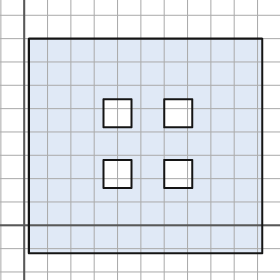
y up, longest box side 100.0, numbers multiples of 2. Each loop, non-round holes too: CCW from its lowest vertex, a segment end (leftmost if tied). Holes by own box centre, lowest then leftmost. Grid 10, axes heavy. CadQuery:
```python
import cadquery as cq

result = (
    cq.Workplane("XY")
    .moveTo(2.0, -12.0)
    .lineTo(102.0, -12.0)
    .lineTo(102.0, 80.0)
    .lineTo(2.0, 80.0)
    .close()
    .moveTo(34.0, 16.0)
    .lineTo(46.0, 16.0)
    .lineTo(46.0, 28.0)
    .lineTo(34.0, 28.0)
    .close()
    .moveTo(60.0, 16.0)
    .lineTo(72.0, 16.0)
    .lineTo(72.0, 28.0)
    .lineTo(60.0, 28.0)
    .close()
    .moveTo(34.0, 42.0)
    .lineTo(46.0, 42.0)
    .lineTo(46.0, 54.0)
    .lineTo(34.0, 54.0)
    .close()
    .moveTo(60.0, 42.0)
    .lineTo(72.0, 42.0)
    .lineTo(72.0, 54.0)
    .lineTo(60.0, 54.0)
    .close()
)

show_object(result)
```